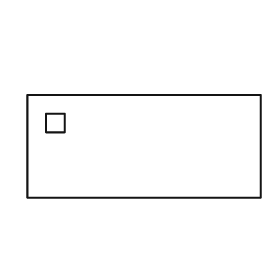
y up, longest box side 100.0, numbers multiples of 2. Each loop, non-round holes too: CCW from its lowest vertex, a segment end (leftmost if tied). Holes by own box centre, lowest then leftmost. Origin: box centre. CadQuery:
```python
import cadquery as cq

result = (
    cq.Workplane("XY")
    .moveTo(-50.0, -22.0)
    .lineTo(50.0, -22.0)
    .lineTo(50.0, 22.0)
    .lineTo(-50.0, 22.0)
    .close()
    .moveTo(-42.0, 6.0)
    .lineTo(-34.0, 6.0)
    .lineTo(-34.0, 14.0)
    .lineTo(-42.0, 14.0)
    .close()
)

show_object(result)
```